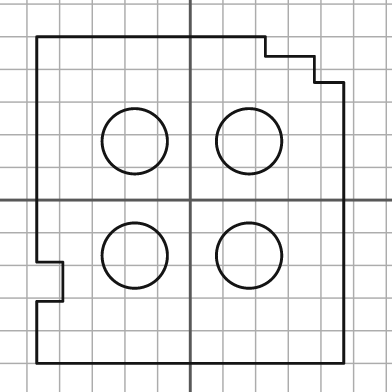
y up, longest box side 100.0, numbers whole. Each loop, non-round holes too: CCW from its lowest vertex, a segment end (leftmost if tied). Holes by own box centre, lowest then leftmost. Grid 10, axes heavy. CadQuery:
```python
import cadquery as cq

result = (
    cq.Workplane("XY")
    .moveTo(-47.0, -50.0)
    .lineTo(47.0, -50.0)
    .lineTo(47.0, 36.0)
    .lineTo(38.0, 36.0)
    .lineTo(38.0, 44.0)
    .lineTo(23.0, 44.0)
    .lineTo(23.0, 50.0)
    .lineTo(-47.0, 50.0)
    .lineTo(-47.0, -19.0)
    .lineTo(-39.0, -19.0)
    .lineTo(-39.0, -31.0)
    .lineTo(-47.0, -31.0)
    .close()
    .moveTo(-17.0, -17.0)
    .circle(10.0)
    .moveTo(18.0, -17.0)
    .circle(10.0)
    .moveTo(-17.0, 18.0)
    .circle(10.0)
    .moveTo(18.0, 18.0)
    .circle(10.0)
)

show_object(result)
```